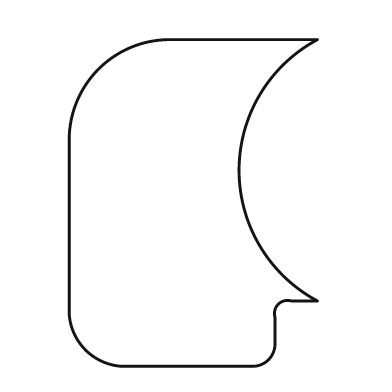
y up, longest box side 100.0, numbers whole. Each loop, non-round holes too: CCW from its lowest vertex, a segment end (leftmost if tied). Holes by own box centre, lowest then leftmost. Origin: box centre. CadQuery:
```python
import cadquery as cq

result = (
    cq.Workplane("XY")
    .moveTo(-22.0, -50.0)
    .lineTo(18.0, -50.0)
    .threePointArc((23.0, -48.0), (25.0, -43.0))
    .lineTo(25.0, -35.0)
    .threePointArc((26.0, -31.0), (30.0, -30.0))
    .lineTo(38.0, -30.0)
    .threePointArc((14.0, 10.0), (38.0, 50.0))
    .lineTo(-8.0, 50.0)
    .threePointArc((-29.0, 41.0), (-38.0, 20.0))
    .lineTo(-38.0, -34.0)
    .threePointArc((-33.0, -45.0), (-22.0, -50.0))
    .close()
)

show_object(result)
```